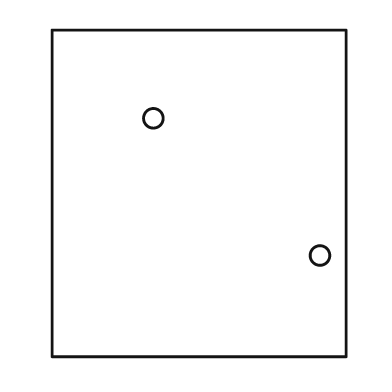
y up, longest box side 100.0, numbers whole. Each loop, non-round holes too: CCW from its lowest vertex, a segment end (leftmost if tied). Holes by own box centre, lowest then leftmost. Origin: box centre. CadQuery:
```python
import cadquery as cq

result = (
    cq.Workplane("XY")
    .moveTo(-45.0, -50.0)
    .lineTo(45.0, -50.0)
    .lineTo(45.0, 50.0)
    .lineTo(-45.0, 50.0)
    .close()
    .moveTo(37.0, -19.0)
    .circle(3.0)
    .moveTo(-14.0, 23.0)
    .circle(3.0)
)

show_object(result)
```